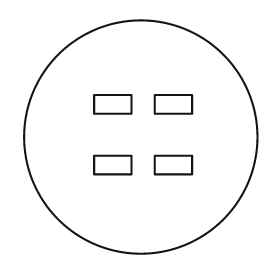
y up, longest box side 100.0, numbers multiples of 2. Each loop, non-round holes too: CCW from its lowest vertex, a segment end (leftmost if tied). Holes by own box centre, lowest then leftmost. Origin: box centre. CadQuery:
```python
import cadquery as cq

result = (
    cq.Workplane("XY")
    .moveTo(0.0, 0.0)
    .circle(50.0)
    .moveTo(-20.0, -16.0)
    .lineTo(-4.0, -16.0)
    .lineTo(-4.0, -8.0)
    .lineTo(-20.0, -8.0)
    .close()
    .moveTo(6.0, -16.0)
    .lineTo(22.0, -16.0)
    .lineTo(22.0, -8.0)
    .lineTo(6.0, -8.0)
    .close()
    .moveTo(-20.0, 10.0)
    .lineTo(-4.0, 10.0)
    .lineTo(-4.0, 18.0)
    .lineTo(-20.0, 18.0)
    .close()
    .moveTo(6.0, 10.0)
    .lineTo(22.0, 10.0)
    .lineTo(22.0, 18.0)
    .lineTo(6.0, 18.0)
    .close()
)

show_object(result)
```